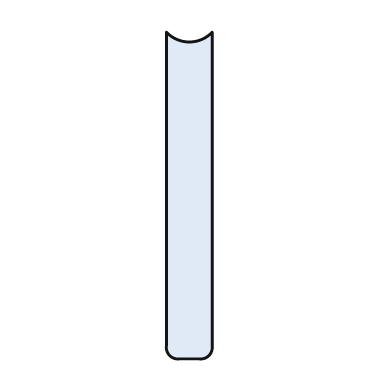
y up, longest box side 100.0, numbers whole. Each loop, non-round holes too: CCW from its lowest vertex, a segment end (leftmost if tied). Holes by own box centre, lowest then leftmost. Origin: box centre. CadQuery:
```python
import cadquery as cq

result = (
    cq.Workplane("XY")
    .moveTo(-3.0, -50.0)
    .lineTo(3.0, -50.0)
    .threePointArc((6.0, -49.0), (7.0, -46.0))
    .lineTo(7.0, 50.0)
    .threePointArc((0.0, 47.0), (-7.0, 50.0))
    .lineTo(-7.0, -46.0)
    .threePointArc((-6.0, -49.0), (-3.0, -50.0))
    .close()
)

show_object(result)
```